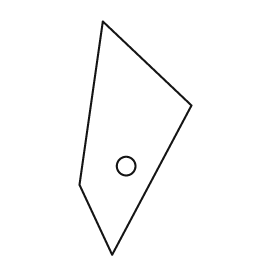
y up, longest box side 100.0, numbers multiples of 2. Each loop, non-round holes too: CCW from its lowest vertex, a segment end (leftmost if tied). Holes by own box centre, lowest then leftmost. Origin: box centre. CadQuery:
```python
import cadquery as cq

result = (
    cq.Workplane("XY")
    .moveTo(-10.0, -50.0)
    .lineTo(24.0, 14.0)
    .lineTo(-14.0, 50.0)
    .lineTo(-24.0, -20.0)
    .close()
    .moveTo(-4.0, -12.0)
    .circle(4.0)
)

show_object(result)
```